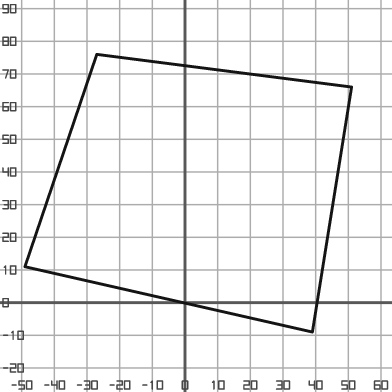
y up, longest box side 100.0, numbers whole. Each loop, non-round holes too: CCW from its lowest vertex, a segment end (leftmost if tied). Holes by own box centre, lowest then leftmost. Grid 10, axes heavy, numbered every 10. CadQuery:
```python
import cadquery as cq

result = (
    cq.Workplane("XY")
    .moveTo(39.0, -9.0)
    .lineTo(51.0, 66.0)
    .lineTo(-27.0, 76.0)
    .lineTo(-49.0, 11.0)
    .close()
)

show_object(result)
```